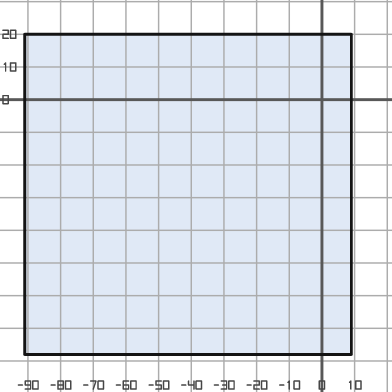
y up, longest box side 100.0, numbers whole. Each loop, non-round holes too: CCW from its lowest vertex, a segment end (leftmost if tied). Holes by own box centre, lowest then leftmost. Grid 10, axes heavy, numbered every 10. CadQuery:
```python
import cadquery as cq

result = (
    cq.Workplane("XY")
    .moveTo(-91.0, -78.0)
    .lineTo(9.0, -78.0)
    .lineTo(9.0, 20.0)
    .lineTo(-91.0, 20.0)
    .close()
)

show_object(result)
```